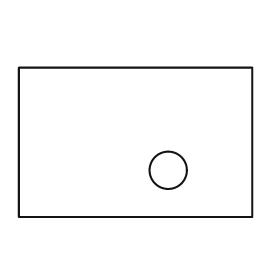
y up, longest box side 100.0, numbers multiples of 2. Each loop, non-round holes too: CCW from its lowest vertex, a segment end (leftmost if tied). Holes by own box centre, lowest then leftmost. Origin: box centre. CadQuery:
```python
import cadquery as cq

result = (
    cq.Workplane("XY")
    .moveTo(-50.0, -32.0)
    .lineTo(50.0, -32.0)
    .lineTo(50.0, 32.0)
    .lineTo(-50.0, 32.0)
    .close()
    .moveTo(14.0, -12.0)
    .circle(8.0)
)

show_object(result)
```